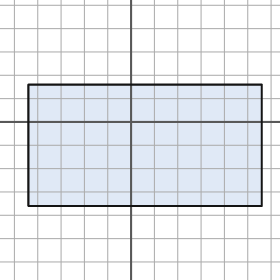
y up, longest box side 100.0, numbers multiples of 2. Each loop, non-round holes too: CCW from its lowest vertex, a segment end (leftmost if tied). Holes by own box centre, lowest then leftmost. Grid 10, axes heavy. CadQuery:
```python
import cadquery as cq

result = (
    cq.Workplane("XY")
    .moveTo(-44.0, -36.0)
    .lineTo(56.0, -36.0)
    .lineTo(56.0, 16.0)
    .lineTo(-44.0, 16.0)
    .close()
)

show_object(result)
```